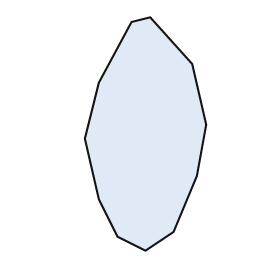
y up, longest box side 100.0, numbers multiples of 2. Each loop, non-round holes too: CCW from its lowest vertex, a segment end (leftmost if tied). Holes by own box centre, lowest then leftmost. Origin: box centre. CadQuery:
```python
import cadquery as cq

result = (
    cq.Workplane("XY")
    .moveTo(0.0, -50.0)
    .lineTo(12.0, -42.0)
    .lineTo(22.0, -18.0)
    .lineTo(26.0, 4.0)
    .lineTo(20.0, 30.0)
    .lineTo(2.0, 50.0)
    .lineTo(-6.0, 48.0)
    .lineTo(-20.0, 22.0)
    .lineTo(-26.0, -2.0)
    .lineTo(-20.0, -28.0)
    .lineTo(-12.0, -44.0)
    .close()
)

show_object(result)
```